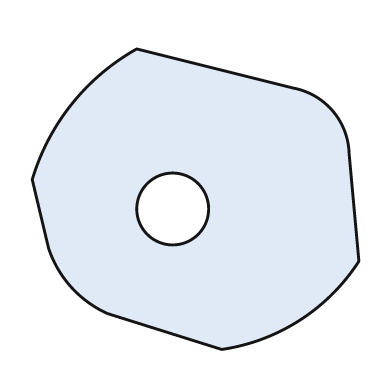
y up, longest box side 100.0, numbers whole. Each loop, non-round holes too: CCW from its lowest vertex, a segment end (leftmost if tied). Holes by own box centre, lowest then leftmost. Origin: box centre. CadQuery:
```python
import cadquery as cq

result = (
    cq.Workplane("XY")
    .moveTo(8.0, -46.0)
    .threePointArc((32.0, -37.0), (50.0, -19.0))
    .lineTo(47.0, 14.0)
    .threePointArc((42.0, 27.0), (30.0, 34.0))
    .lineTo(-18.0, 46.0)
    .threePointArc((-38.0, 29.0), (-50.0, 6.0))
    .lineTo(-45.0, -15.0)
    .threePointArc((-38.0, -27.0), (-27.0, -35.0))
    .close()
    .moveTo(-7.0, -3.0)
    .circle(11.0)
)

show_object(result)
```